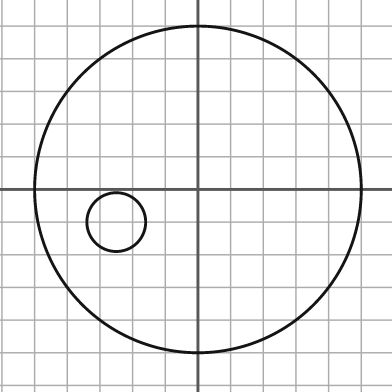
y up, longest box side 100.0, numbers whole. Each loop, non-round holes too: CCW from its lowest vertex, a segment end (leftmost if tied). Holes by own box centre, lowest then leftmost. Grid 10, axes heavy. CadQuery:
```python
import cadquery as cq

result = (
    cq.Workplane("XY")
    .moveTo(0.0, 0.0)
    .circle(50.0)
    .moveTo(-25.0, -10.0)
    .circle(9.0)
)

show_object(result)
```